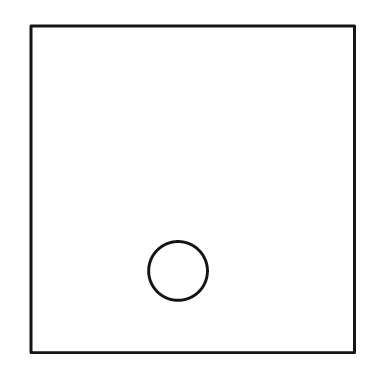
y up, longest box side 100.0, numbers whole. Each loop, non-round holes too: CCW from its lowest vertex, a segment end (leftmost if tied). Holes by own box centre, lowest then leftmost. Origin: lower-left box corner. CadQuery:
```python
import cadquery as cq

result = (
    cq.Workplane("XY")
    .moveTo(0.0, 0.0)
    .lineTo(99.0, 0.0)
    .lineTo(99.0, 100.0)
    .lineTo(0.0, 100.0)
    .close()
    .moveTo(45.0, 25.0)
    .circle(9.0)
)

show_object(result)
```